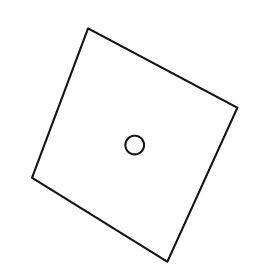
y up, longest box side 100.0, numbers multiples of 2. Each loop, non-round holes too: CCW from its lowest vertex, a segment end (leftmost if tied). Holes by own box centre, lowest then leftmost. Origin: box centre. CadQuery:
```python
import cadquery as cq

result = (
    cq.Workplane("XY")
    .moveTo(14.0, -50.0)
    .lineTo(44.0, 16.0)
    .lineTo(-20.0, 50.0)
    .lineTo(-44.0, -14.0)
    .close()
    .moveTo(0.0, 0.0)
    .circle(4.0)
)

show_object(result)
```